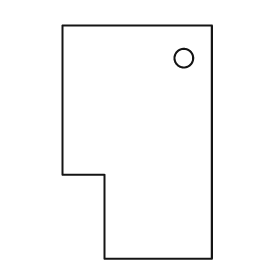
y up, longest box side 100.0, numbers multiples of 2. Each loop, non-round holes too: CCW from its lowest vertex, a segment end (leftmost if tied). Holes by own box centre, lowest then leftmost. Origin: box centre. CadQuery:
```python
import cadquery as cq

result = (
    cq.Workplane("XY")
    .moveTo(-14.0, -50.0)
    .lineTo(32.0, -50.0)
    .lineTo(32.0, 50.0)
    .lineTo(-32.0, 50.0)
    .lineTo(-32.0, -14.0)
    .lineTo(-14.0, -14.0)
    .close()
    .moveTo(20.0, 36.0)
    .circle(4.0)
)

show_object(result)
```